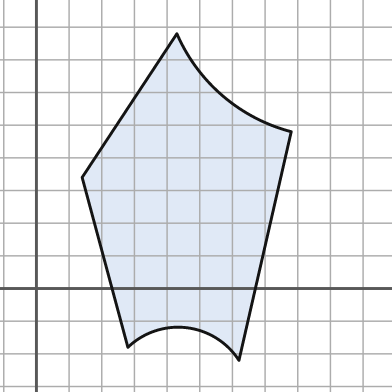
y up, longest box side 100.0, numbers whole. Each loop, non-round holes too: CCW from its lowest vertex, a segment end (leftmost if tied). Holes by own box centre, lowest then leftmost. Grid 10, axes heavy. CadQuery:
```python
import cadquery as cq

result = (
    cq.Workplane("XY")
    .moveTo(62.0, -22.0)
    .lineTo(78.0, 48.0)
    .threePointArc((57.0, 59.0), (43.0, 78.0))
    .lineTo(14.0, 34.0)
    .lineTo(28.0, -18.0)
    .threePointArc((46.0, -12.0), (62.0, -22.0))
    .close()
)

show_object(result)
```